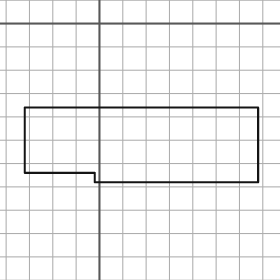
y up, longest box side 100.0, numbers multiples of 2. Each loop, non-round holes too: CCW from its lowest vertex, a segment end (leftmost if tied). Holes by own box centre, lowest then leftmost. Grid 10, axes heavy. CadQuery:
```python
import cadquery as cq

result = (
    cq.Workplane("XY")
    .moveTo(-2.0, -68.0)
    .lineTo(68.0, -68.0)
    .lineTo(68.0, -36.0)
    .lineTo(-32.0, -36.0)
    .lineTo(-32.0, -64.0)
    .lineTo(-2.0, -64.0)
    .close()
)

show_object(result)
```